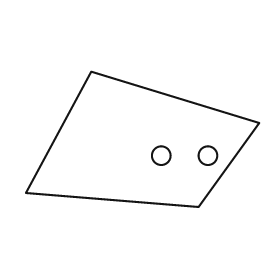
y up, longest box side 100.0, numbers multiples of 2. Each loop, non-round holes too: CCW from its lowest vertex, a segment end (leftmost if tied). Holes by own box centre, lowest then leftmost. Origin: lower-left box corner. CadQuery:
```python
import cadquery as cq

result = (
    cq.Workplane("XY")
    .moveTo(74.0, 0.0)
    .lineTo(100.0, 36.0)
    .lineTo(28.0, 58.0)
    .lineTo(0.0, 6.0)
    .close()
    .moveTo(58.0, 22.0)
    .circle(4.0)
    .moveTo(78.0, 22.0)
    .circle(4.0)
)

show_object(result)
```